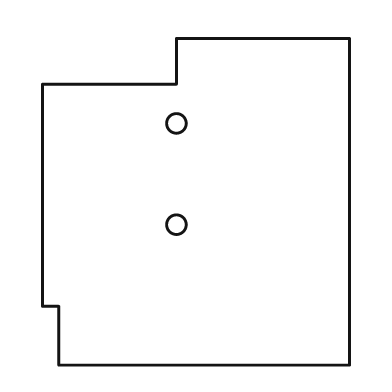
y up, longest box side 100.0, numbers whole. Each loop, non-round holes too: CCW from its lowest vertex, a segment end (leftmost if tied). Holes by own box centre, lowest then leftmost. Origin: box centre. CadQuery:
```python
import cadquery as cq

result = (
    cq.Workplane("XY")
    .moveTo(-42.0, -50.0)
    .lineTo(47.0, -50.0)
    .lineTo(47.0, 50.0)
    .lineTo(-6.0, 50.0)
    .lineTo(-6.0, 36.0)
    .lineTo(-47.0, 36.0)
    .lineTo(-47.0, -32.0)
    .lineTo(-42.0, -32.0)
    .close()
    .moveTo(-6.0, -7.0)
    .circle(3.0)
    .moveTo(-6.0, 24.0)
    .circle(3.0)
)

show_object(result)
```